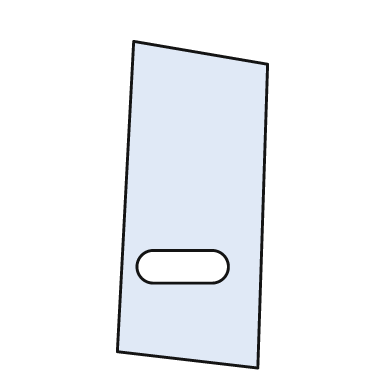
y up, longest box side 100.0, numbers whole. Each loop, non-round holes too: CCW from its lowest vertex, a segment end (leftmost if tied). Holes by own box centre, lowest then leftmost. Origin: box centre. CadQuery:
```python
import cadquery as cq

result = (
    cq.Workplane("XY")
    .moveTo(20.0, -50.0)
    .lineTo(23.0, 43.0)
    .lineTo(-18.0, 50.0)
    .lineTo(-23.0, -45.0)
    .close()
    .moveTo(-12.0, -24.0)
    .lineTo(6.0, -24.0)
    .threePointArc((11.0, -19.0), (6.0, -14.0))
    .lineTo(-12.0, -14.0)
    .threePointArc((-17.0, -19.0), (-12.0, -24.0))
    .close()
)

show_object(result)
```